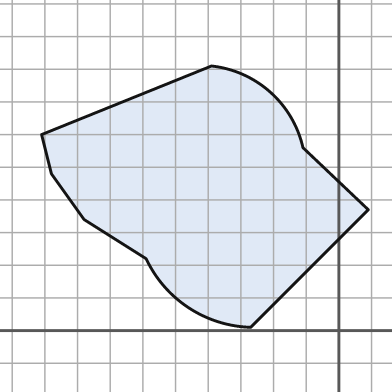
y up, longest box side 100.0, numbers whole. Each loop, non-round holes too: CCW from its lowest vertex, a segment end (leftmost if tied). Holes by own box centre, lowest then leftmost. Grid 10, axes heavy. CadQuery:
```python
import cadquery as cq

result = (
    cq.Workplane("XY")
    .moveTo(-27.0, 1.0)
    .lineTo(9.0, 37.0)
    .lineTo(-11.0, 56.0)
    .threePointArc((-21.0, 73.0), (-39.0, 81.0))
    .lineTo(-91.0, 60.0)
    .lineTo(-88.0, 48.0)
    .lineTo(-78.0, 34.0)
    .lineTo(-59.0, 22.0)
    .threePointArc((-46.0, 7.0), (-27.0, 1.0))
    .close()
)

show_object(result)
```